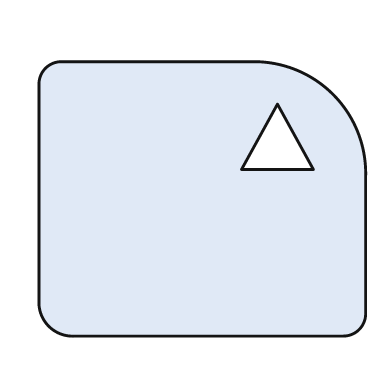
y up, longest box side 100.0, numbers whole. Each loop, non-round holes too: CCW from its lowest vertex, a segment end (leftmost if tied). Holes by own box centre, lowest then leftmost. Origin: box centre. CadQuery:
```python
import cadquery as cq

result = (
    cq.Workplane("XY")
    .moveTo(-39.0, -42.0)
    .lineTo(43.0, -42.0)
    .threePointArc((48.0, -40.0), (50.0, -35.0))
    .lineTo(50.0, 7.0)
    .threePointArc((40.0, 32.0), (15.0, 42.0))
    .lineTo(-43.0, 42.0)
    .threePointArc((-48.0, 40.0), (-50.0, 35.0))
    .lineTo(-50.0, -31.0)
    .threePointArc((-47.0, -39.0), (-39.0, -42.0))
    .close()
    .moveTo(12.0, 9.0)
    .lineTo(34.0, 9.0)
    .lineTo(23.0, 29.0)
    .close()
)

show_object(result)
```